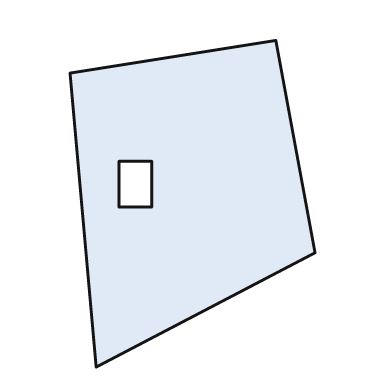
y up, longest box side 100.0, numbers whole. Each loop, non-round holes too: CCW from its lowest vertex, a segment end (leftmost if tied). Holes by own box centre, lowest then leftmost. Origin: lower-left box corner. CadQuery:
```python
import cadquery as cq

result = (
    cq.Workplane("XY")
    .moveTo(8.0, 0.0)
    .lineTo(75.0, 35.0)
    .lineTo(63.0, 100.0)
    .lineTo(0.0, 90.0)
    .close()
    .moveTo(15.0, 49.0)
    .lineTo(25.0, 49.0)
    .lineTo(25.0, 63.0)
    .lineTo(15.0, 63.0)
    .close()
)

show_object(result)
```